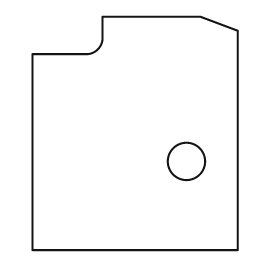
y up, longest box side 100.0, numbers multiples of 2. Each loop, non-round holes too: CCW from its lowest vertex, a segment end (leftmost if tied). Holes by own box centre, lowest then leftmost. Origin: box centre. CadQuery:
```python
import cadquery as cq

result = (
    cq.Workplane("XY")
    .moveTo(-44.0, -50.0)
    .lineTo(44.0, -50.0)
    .lineTo(44.0, 44.0)
    .lineTo(28.0, 50.0)
    .lineTo(-14.0, 50.0)
    .lineTo(-14.0, 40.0)
    .threePointArc((-16.0, 36.0), (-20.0, 34.0))
    .lineTo(-44.0, 34.0)
    .close()
    .moveTo(22.0, -12.0)
    .circle(8.0)
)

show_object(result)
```